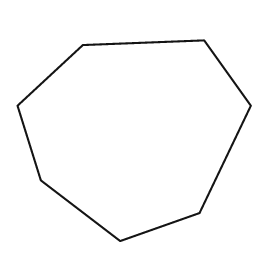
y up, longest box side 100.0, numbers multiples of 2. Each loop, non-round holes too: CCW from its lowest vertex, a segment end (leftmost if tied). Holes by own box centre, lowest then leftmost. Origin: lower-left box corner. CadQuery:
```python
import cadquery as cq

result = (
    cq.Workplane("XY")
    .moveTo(44.0, 0.0)
    .lineTo(78.0, 12.0)
    .lineTo(100.0, 58.0)
    .lineTo(80.0, 86.0)
    .lineTo(28.0, 84.0)
    .lineTo(0.0, 58.0)
    .lineTo(10.0, 26.0)
    .close()
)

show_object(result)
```